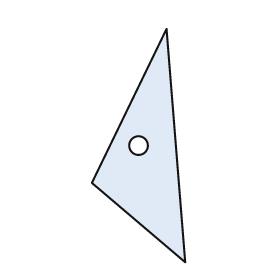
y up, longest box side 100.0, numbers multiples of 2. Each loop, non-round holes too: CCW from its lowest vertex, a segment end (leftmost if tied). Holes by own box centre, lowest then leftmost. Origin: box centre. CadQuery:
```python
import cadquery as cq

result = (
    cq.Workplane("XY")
    .moveTo(20.0, -50.0)
    .lineTo(12.0, 50.0)
    .lineTo(-20.0, -16.0)
    .close()
    .moveTo(0.0, 0.0)
    .circle(4.0)
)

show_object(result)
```